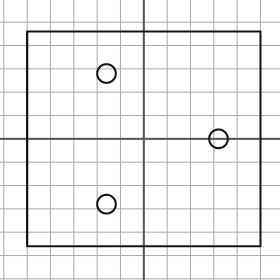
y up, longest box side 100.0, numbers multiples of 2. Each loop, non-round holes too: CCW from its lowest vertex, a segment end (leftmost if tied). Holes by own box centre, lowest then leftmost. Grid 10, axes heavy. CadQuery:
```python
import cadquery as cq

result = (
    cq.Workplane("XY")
    .moveTo(-50.0, -46.0)
    .lineTo(50.0, -46.0)
    .lineTo(50.0, 46.0)
    .lineTo(-50.0, 46.0)
    .close()
    .moveTo(-16.0, -28.0)
    .circle(4.0)
    .moveTo(32.0, 0.0)
    .circle(4.0)
    .moveTo(-16.0, 28.0)
    .circle(4.0)
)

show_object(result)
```